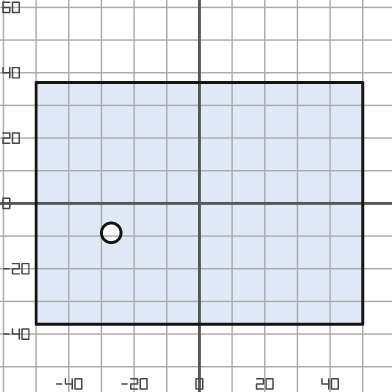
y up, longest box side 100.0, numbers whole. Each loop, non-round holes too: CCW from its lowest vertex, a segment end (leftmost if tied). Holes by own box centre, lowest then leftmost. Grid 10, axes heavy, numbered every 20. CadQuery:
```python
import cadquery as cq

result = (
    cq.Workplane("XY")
    .moveTo(-50.0, -37.0)
    .lineTo(50.0, -37.0)
    .lineTo(50.0, 37.0)
    .lineTo(-50.0, 37.0)
    .close()
    .moveTo(-27.0, -9.0)
    .circle(3.0)
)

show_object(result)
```